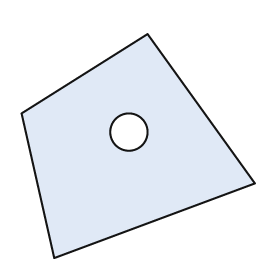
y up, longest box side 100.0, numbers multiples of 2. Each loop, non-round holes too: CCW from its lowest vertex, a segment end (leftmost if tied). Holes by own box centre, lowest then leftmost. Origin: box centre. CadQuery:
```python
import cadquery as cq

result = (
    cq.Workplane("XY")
    .moveTo(-36.0, -48.0)
    .lineTo(50.0, -16.0)
    .lineTo(4.0, 48.0)
    .lineTo(-50.0, 14.0)
    .close()
    .moveTo(-4.0, 6.0)
    .circle(8.0)
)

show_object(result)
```